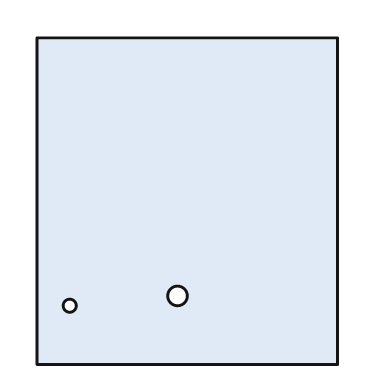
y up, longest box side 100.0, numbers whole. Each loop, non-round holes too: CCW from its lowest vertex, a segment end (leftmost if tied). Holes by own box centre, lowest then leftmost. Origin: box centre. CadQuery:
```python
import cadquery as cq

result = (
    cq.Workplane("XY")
    .moveTo(-46.0, -50.0)
    .lineTo(46.0, -50.0)
    .lineTo(46.0, 50.0)
    .lineTo(-46.0, 50.0)
    .close()
    .moveTo(-36.0, -32.0)
    .circle(2.0)
    .moveTo(-3.0, -29.0)
    .circle(3.0)
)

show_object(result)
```